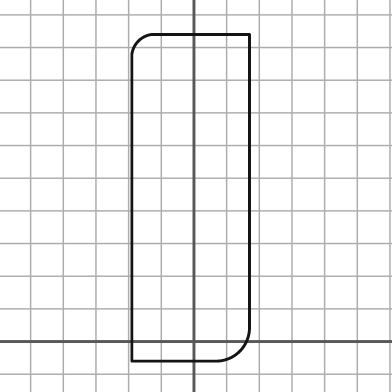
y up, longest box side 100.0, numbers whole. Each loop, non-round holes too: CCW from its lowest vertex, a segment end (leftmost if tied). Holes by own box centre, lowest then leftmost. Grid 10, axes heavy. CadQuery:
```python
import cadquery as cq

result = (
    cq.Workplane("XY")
    .moveTo(-19.0, -6.0)
    .lineTo(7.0, -6.0)
    .threePointArc((14.0, -3.0), (17.0, 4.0))
    .lineTo(17.0, 94.0)
    .lineTo(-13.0, 94.0)
    .threePointArc((-17.0, 92.0), (-19.0, 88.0))
    .close()
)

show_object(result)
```